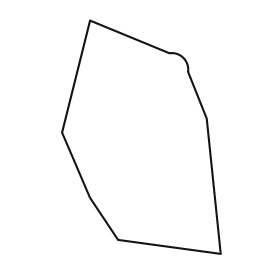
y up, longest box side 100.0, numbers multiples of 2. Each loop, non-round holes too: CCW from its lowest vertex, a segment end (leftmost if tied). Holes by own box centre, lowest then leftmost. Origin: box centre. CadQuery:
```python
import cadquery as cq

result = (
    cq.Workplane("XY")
    .moveTo(34.0, -50.0)
    .lineTo(28.0, 8.0)
    .lineTo(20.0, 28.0)
    .threePointArc((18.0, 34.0), (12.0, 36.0))
    .lineTo(-22.0, 50.0)
    .lineTo(-34.0, 2.0)
    .lineTo(-22.0, -26.0)
    .lineTo(-10.0, -44.0)
    .close()
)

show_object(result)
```